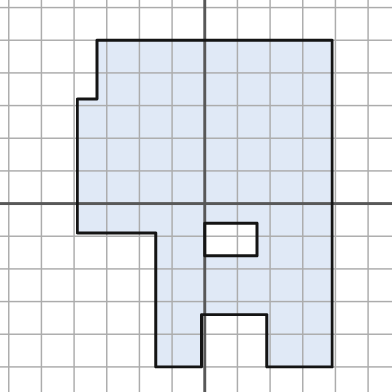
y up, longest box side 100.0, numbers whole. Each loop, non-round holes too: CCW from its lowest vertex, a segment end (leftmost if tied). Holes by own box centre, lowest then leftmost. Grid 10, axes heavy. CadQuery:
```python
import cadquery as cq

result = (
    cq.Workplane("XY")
    .moveTo(-15.0, -50.0)
    .lineTo(-1.0, -50.0)
    .lineTo(-1.0, -34.0)
    .lineTo(19.0, -34.0)
    .lineTo(19.0, -50.0)
    .lineTo(39.0, -50.0)
    .lineTo(39.0, 50.0)
    .lineTo(-33.0, 50.0)
    .lineTo(-33.0, 32.0)
    .lineTo(-39.0, 32.0)
    .lineTo(-39.0, -9.0)
    .lineTo(-15.0, -9.0)
    .close()
    .moveTo(0.0, -16.0)
    .lineTo(16.0, -16.0)
    .lineTo(16.0, -6.0)
    .lineTo(0.0, -6.0)
    .close()
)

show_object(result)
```